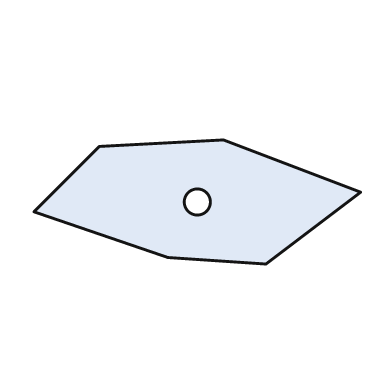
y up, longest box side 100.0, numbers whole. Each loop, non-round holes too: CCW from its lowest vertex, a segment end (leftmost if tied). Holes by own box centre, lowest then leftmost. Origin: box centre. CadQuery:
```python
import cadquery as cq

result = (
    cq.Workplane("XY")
    .moveTo(21.0, -19.0)
    .lineTo(50.0, 3.0)
    .lineTo(8.0, 19.0)
    .lineTo(-30.0, 17.0)
    .lineTo(-50.0, -3.0)
    .lineTo(-9.0, -17.0)
    .close()
    .moveTo(0.0, 0.0)
    .circle(4.0)
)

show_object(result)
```